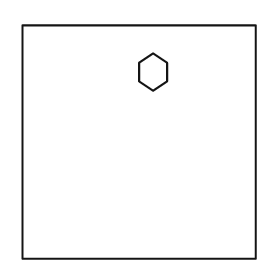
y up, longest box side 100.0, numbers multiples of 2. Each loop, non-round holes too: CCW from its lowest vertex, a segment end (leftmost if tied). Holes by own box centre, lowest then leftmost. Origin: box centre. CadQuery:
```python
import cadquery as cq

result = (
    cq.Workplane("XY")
    .moveTo(-50.0, -50.0)
    .lineTo(50.0, -50.0)
    .lineTo(50.0, 50.0)
    .lineTo(-50.0, 50.0)
    .close()
    .moveTo(6.0, 22.0)
    .lineTo(12.0, 26.0)
    .lineTo(12.0, 34.0)
    .lineTo(6.0, 38.0)
    .lineTo(0.0, 34.0)
    .lineTo(0.0, 26.0)
    .close()
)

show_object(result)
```